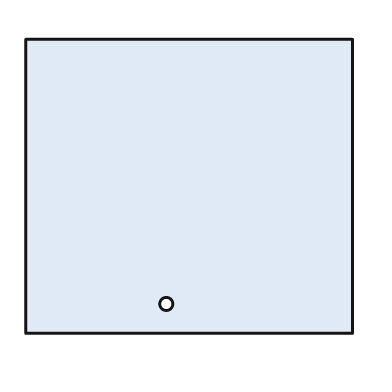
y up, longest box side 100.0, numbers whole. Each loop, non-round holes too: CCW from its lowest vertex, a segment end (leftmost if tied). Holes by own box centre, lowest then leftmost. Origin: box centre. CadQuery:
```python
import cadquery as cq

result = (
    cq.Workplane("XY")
    .moveTo(-50.0, -45.0)
    .lineTo(50.0, -45.0)
    .lineTo(50.0, 45.0)
    .lineTo(-50.0, 45.0)
    .close()
    .moveTo(-7.0, -36.0)
    .circle(2.0)
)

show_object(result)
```